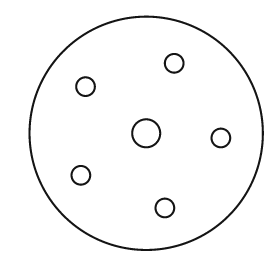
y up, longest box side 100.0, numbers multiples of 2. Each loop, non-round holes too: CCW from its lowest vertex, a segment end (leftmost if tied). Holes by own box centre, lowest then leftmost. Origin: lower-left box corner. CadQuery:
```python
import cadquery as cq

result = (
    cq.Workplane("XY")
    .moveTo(50.0, 50.0)
    .circle(50.0)
    .moveTo(58.0, 18.0)
    .circle(4.0)
    .moveTo(22.0, 32.0)
    .circle(4.0)
    .moveTo(82.0, 48.0)
    .circle(4.0)
    .moveTo(50.0, 50.0)
    .circle(6.0)
    .moveTo(24.0, 70.0)
    .circle(4.0)
    .moveTo(62.0, 80.0)
    .circle(4.0)
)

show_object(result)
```